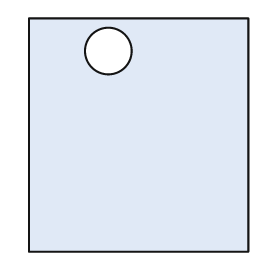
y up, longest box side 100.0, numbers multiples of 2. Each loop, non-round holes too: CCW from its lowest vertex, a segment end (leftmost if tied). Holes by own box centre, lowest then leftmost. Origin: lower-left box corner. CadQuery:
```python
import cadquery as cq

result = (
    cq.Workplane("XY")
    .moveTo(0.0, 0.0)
    .lineTo(94.0, 0.0)
    .lineTo(94.0, 100.0)
    .lineTo(0.0, 100.0)
    .close()
    .moveTo(34.0, 86.0)
    .circle(10.0)
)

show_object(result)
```